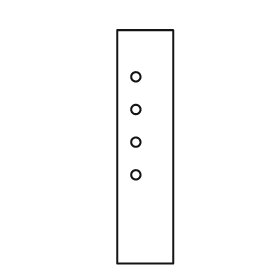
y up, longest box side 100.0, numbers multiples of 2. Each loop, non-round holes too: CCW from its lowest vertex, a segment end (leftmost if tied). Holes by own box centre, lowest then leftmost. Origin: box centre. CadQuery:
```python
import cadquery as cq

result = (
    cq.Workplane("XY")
    .moveTo(-12.0, -50.0)
    .lineTo(12.0, -50.0)
    .lineTo(12.0, 50.0)
    .lineTo(-12.0, 50.0)
    .close()
    .moveTo(-4.0, -12.0)
    .circle(2.0)
    .moveTo(-4.0, 2.0)
    .circle(2.0)
    .moveTo(-4.0, 16.0)
    .circle(2.0)
    .moveTo(-4.0, 30.0)
    .circle(2.0)
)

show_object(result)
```